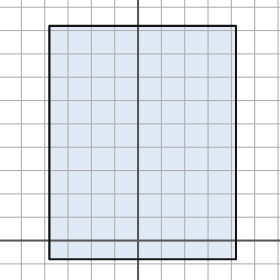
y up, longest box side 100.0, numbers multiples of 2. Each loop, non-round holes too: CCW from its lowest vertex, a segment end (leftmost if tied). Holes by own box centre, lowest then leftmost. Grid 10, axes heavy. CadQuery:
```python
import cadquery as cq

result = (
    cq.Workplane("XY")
    .moveTo(-38.0, -8.0)
    .lineTo(42.0, -8.0)
    .lineTo(42.0, 92.0)
    .lineTo(-38.0, 92.0)
    .close()
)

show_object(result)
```